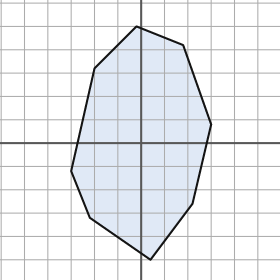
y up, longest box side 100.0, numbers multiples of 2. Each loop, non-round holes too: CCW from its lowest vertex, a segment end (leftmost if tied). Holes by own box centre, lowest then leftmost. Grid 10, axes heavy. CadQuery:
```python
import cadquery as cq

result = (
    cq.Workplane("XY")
    .moveTo(4.0, -50.0)
    .lineTo(22.0, -26.0)
    .lineTo(30.0, 8.0)
    .lineTo(18.0, 42.0)
    .lineTo(-2.0, 50.0)
    .lineTo(-20.0, 32.0)
    .lineTo(-30.0, -12.0)
    .lineTo(-22.0, -32.0)
    .close()
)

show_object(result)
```